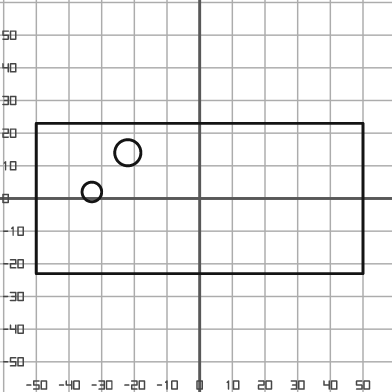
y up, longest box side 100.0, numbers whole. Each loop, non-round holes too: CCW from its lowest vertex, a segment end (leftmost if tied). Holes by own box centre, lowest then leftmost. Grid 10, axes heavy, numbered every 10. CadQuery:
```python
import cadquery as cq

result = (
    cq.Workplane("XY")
    .moveTo(-50.0, -23.0)
    .lineTo(50.0, -23.0)
    .lineTo(50.0, 23.0)
    .lineTo(-50.0, 23.0)
    .close()
    .moveTo(-33.0, 2.0)
    .circle(3.0)
    .moveTo(-22.0, 14.0)
    .circle(4.0)
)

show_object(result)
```